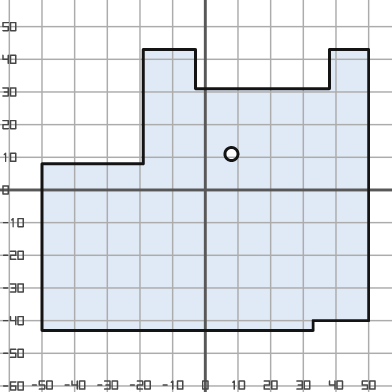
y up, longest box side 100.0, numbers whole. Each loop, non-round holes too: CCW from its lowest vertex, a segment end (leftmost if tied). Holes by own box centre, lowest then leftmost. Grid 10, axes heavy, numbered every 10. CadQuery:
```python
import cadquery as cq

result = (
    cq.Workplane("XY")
    .moveTo(-50.0, -43.0)
    .lineTo(33.0, -43.0)
    .lineTo(33.0, -40.0)
    .lineTo(50.0, -40.0)
    .lineTo(50.0, 43.0)
    .lineTo(38.0, 43.0)
    .lineTo(38.0, 31.0)
    .lineTo(-3.0, 31.0)
    .lineTo(-3.0, 43.0)
    .lineTo(-19.0, 43.0)
    .lineTo(-19.0, 8.0)
    .lineTo(-50.0, 8.0)
    .close()
    .moveTo(8.0, 11.0)
    .circle(2.0)
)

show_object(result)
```